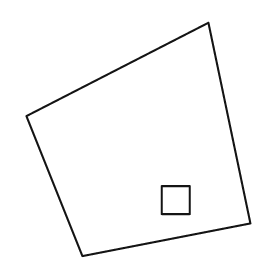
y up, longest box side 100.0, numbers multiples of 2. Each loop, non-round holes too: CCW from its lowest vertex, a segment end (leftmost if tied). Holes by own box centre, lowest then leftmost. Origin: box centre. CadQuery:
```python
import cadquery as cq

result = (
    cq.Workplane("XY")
    .moveTo(-24.0, -50.0)
    .lineTo(48.0, -36.0)
    .lineTo(30.0, 50.0)
    .lineTo(-48.0, 10.0)
    .close()
    .moveTo(10.0, -32.0)
    .lineTo(22.0, -32.0)
    .lineTo(22.0, -20.0)
    .lineTo(10.0, -20.0)
    .close()
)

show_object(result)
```